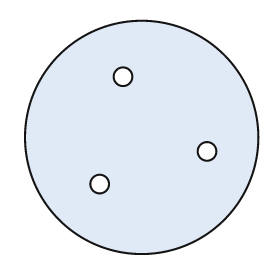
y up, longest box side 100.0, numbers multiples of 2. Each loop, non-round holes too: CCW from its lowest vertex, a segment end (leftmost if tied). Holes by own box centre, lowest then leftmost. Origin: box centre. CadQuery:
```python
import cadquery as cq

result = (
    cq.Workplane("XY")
    .moveTo(0.0, 0.0)
    .circle(50.0)
    .moveTo(-18.0, -20.0)
    .circle(4.0)
    .moveTo(28.0, -6.0)
    .circle(4.0)
    .moveTo(-8.0, 26.0)
    .circle(4.0)
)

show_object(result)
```